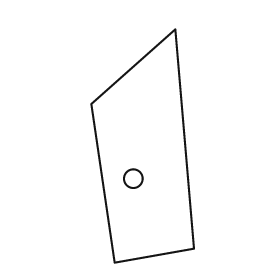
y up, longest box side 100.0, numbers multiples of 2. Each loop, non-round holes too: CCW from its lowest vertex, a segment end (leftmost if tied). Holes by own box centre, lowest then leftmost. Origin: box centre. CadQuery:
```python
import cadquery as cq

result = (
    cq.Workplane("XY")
    .moveTo(-12.0, -50.0)
    .lineTo(22.0, -44.0)
    .lineTo(14.0, 50.0)
    .lineTo(-22.0, 18.0)
    .close()
    .moveTo(-4.0, -14.0)
    .circle(4.0)
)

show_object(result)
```